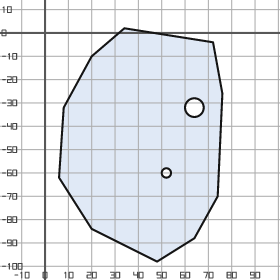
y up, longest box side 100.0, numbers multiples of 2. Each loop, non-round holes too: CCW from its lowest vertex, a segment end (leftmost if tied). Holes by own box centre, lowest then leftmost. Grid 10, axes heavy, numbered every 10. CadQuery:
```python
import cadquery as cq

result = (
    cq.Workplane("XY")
    .moveTo(48.0, -98.0)
    .lineTo(64.0, -88.0)
    .lineTo(74.0, -70.0)
    .lineTo(76.0, -26.0)
    .lineTo(72.0, -4.0)
    .lineTo(34.0, 2.0)
    .lineTo(20.0, -10.0)
    .lineTo(8.0, -32.0)
    .lineTo(6.0, -62.0)
    .lineTo(20.0, -84.0)
    .close()
    .moveTo(52.0, -60.0)
    .circle(2.0)
    .moveTo(64.0, -32.0)
    .circle(4.0)
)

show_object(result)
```